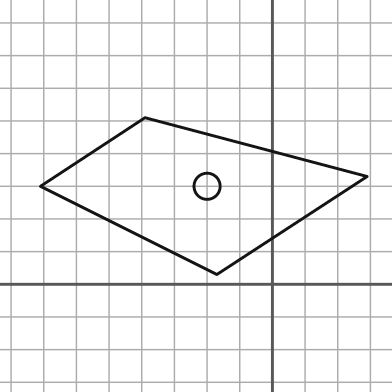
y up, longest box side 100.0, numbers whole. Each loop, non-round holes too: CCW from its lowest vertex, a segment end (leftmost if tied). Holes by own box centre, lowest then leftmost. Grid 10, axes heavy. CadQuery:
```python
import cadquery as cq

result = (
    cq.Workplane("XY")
    .moveTo(-17.0, 3.0)
    .lineTo(29.0, 33.0)
    .lineTo(-39.0, 51.0)
    .lineTo(-71.0, 30.0)
    .close()
    .moveTo(-20.0, 30.0)
    .circle(4.0)
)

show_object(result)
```